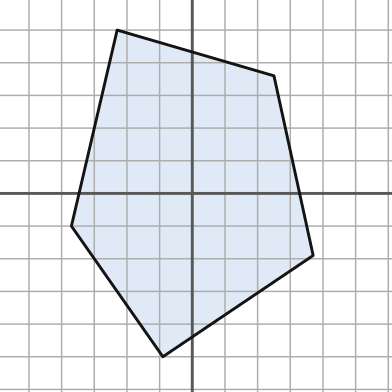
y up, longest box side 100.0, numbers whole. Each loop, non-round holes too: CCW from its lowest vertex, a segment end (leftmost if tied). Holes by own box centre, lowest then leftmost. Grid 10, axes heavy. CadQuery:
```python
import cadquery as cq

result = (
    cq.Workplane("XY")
    .moveTo(-9.0, -50.0)
    .lineTo(37.0, -19.0)
    .lineTo(25.0, 36.0)
    .lineTo(-23.0, 50.0)
    .lineTo(-37.0, -10.0)
    .close()
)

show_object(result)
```